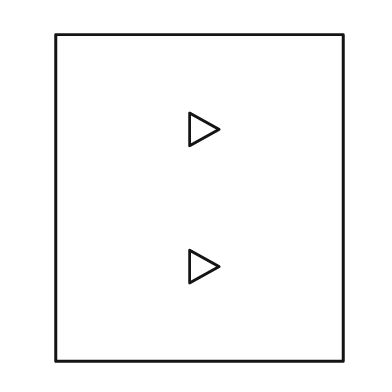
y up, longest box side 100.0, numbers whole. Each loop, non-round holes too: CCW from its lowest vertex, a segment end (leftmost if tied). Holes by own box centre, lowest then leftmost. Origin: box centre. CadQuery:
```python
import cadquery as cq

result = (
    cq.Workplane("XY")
    .moveTo(-44.0, -50.0)
    .lineTo(44.0, -50.0)
    .lineTo(44.0, 50.0)
    .lineTo(-44.0, 50.0)
    .close()
    .moveTo(-3.0, -26.0)
    .lineTo(6.0, -21.0)
    .lineTo(-3.0, -16.0)
    .close()
    .moveTo(-3.0, 16.0)
    .lineTo(6.0, 21.0)
    .lineTo(-3.0, 26.0)
    .close()
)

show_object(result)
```